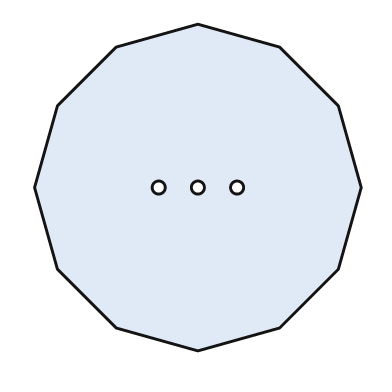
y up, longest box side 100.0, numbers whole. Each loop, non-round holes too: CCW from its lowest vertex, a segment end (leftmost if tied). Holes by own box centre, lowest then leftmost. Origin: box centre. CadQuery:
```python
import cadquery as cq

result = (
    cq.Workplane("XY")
    .moveTo(0.0, -50.0)
    .lineTo(25.0, -43.0)
    .lineTo(43.0, -25.0)
    .lineTo(50.0, 0.0)
    .lineTo(43.0, 25.0)
    .lineTo(25.0, 43.0)
    .lineTo(0.0, 50.0)
    .lineTo(-25.0, 43.0)
    .lineTo(-43.0, 25.0)
    .lineTo(-50.0, 0.0)
    .lineTo(-43.0, -25.0)
    .lineTo(-25.0, -43.0)
    .close()
    .moveTo(-12.0, 0.0)
    .circle(2.0)
    .moveTo(0.0, 0.0)
    .circle(2.0)
    .moveTo(12.0, 0.0)
    .circle(2.0)
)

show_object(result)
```